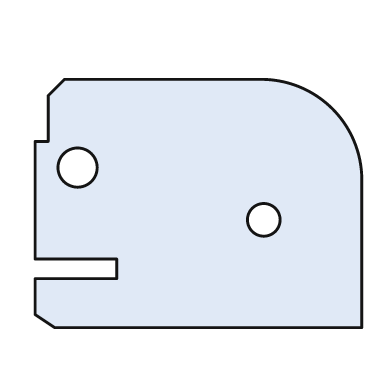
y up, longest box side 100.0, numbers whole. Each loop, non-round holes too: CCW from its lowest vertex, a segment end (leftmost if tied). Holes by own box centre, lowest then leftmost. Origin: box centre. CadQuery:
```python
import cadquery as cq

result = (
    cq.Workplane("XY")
    .moveTo(-44.0, -38.0)
    .lineTo(50.0, -38.0)
    .lineTo(50.0, 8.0)
    .threePointArc((41.0, 29.0), (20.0, 38.0))
    .lineTo(-41.0, 38.0)
    .lineTo(-46.0, 33.0)
    .lineTo(-46.0, 19.0)
    .lineTo(-50.0, 19.0)
    .lineTo(-50.0, -17.0)
    .lineTo(-25.0, -17.0)
    .lineTo(-25.0, -23.0)
    .lineTo(-50.0, -23.0)
    .lineTo(-50.0, -34.0)
    .close()
    .moveTo(20.0, -5.0)
    .circle(5.0)
    .moveTo(-37.0, 11.0)
    .circle(6.0)
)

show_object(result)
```